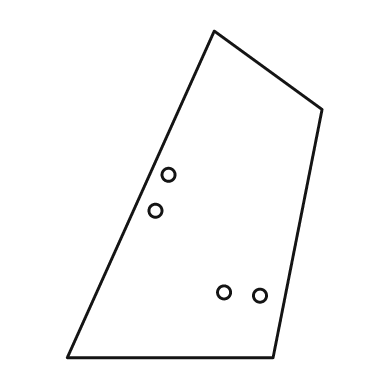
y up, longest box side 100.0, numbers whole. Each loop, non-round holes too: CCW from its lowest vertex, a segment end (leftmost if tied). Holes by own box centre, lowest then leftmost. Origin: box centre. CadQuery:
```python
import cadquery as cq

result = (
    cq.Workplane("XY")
    .moveTo(-39.0, -50.0)
    .lineTo(24.0, -50.0)
    .lineTo(39.0, 26.0)
    .lineTo(6.0, 50.0)
    .close()
    .moveTo(20.0, -31.0)
    .circle(2.0)
    .moveTo(9.0, -30.0)
    .circle(2.0)
    .moveTo(-12.0, -5.0)
    .circle(2.0)
    .moveTo(-8.0, 6.0)
    .circle(2.0)
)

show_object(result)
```